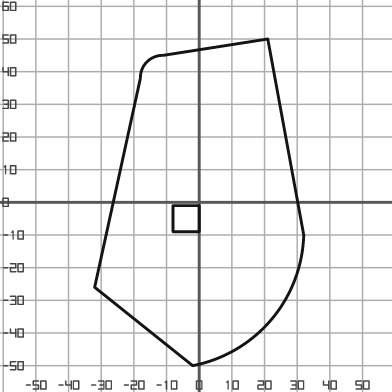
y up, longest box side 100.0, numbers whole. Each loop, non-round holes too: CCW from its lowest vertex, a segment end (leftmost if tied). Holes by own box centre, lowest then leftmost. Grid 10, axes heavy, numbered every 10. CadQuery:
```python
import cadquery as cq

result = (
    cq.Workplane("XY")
    .moveTo(-2.0, -50.0)
    .threePointArc((22.0, -36.0), (32.0, -10.0))
    .lineTo(21.0, 50.0)
    .lineTo(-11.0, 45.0)
    .threePointArc((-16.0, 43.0), (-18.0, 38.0))
    .lineTo(-32.0, -26.0)
    .close()
    .moveTo(-8.0, -9.0)
    .lineTo(0.0, -9.0)
    .lineTo(0.0, -1.0)
    .lineTo(-8.0, -1.0)
    .close()
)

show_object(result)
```